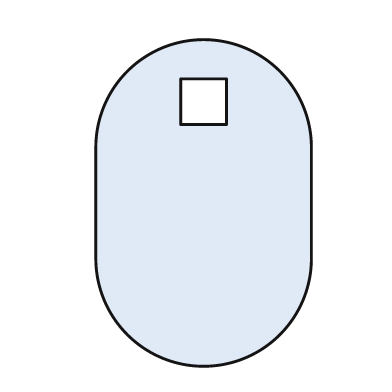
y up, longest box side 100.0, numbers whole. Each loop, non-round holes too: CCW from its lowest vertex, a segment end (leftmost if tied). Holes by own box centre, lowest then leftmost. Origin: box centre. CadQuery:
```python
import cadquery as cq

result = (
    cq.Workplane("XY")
    .moveTo(-33.0, -17.0)
    .threePointArc((0.0, -50.0), (33.0, -17.0))
    .lineTo(33.0, 17.0)
    .threePointArc((0.0, 50.0), (-33.0, 17.0))
    .close()
    .moveTo(-7.0, 24.0)
    .lineTo(7.0, 24.0)
    .lineTo(7.0, 38.0)
    .lineTo(-7.0, 38.0)
    .close()
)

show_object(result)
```